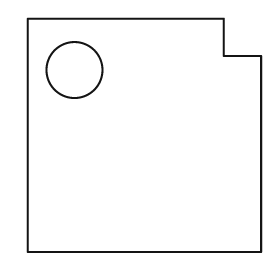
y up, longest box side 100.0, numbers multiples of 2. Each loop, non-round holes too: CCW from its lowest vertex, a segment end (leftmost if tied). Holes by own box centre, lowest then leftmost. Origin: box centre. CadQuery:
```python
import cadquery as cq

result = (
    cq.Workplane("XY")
    .moveTo(-50.0, -50.0)
    .lineTo(50.0, -50.0)
    .lineTo(50.0, 34.0)
    .lineTo(34.0, 34.0)
    .lineTo(34.0, 50.0)
    .lineTo(-50.0, 50.0)
    .close()
    .moveTo(-30.0, 28.0)
    .circle(12.0)
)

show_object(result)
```